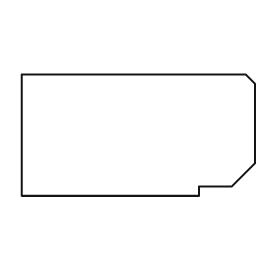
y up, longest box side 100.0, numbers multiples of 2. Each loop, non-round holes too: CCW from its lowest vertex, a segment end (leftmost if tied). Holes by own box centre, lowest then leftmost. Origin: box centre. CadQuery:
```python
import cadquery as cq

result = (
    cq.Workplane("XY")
    .moveTo(-50.0, -26.0)
    .lineTo(26.0, -26.0)
    .lineTo(26.0, -22.0)
    .lineTo(40.0, -22.0)
    .lineTo(50.0, -12.0)
    .lineTo(50.0, 22.0)
    .lineTo(46.0, 26.0)
    .lineTo(-50.0, 26.0)
    .close()
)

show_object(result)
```